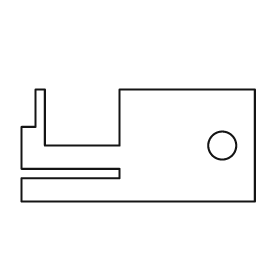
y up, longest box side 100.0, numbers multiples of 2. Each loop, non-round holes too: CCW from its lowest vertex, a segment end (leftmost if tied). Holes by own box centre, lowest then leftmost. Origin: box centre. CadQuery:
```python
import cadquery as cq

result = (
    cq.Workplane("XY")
    .moveTo(-50.0, -24.0)
    .lineTo(50.0, -24.0)
    .lineTo(50.0, 24.0)
    .lineTo(-8.0, 24.0)
    .lineTo(-8.0, 0.0)
    .lineTo(-40.0, 0.0)
    .lineTo(-40.0, 24.0)
    .lineTo(-44.0, 24.0)
    .lineTo(-44.0, 8.0)
    .lineTo(-50.0, 8.0)
    .lineTo(-50.0, -10.0)
    .lineTo(-8.0, -10.0)
    .lineTo(-8.0, -14.0)
    .lineTo(-50.0, -14.0)
    .close()
    .moveTo(36.0, 0.0)
    .circle(6.0)
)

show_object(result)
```